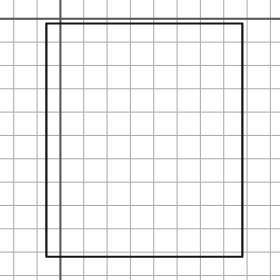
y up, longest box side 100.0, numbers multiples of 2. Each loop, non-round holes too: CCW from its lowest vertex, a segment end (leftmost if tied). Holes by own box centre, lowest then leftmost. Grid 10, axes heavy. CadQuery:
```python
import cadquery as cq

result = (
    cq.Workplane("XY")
    .moveTo(-6.0, -102.0)
    .lineTo(78.0, -102.0)
    .lineTo(78.0, -2.0)
    .lineTo(-6.0, -2.0)
    .close()
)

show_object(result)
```